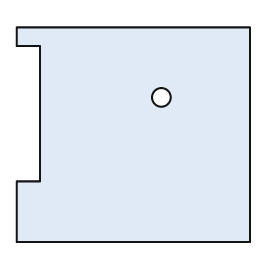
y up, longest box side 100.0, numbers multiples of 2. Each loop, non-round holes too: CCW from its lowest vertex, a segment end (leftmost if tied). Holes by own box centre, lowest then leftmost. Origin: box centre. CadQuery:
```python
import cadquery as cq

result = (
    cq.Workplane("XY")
    .moveTo(-50.0, -46.0)
    .lineTo(50.0, -46.0)
    .lineTo(50.0, 46.0)
    .lineTo(-50.0, 46.0)
    .lineTo(-50.0, 38.0)
    .lineTo(-40.0, 38.0)
    .lineTo(-40.0, -20.0)
    .lineTo(-50.0, -20.0)
    .close()
    .moveTo(12.0, 16.0)
    .circle(4.0)
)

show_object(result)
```